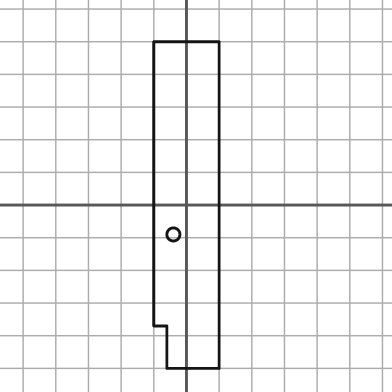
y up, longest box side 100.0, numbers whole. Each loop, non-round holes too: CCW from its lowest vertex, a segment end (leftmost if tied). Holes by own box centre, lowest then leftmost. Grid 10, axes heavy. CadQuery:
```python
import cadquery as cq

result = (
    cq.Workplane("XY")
    .moveTo(-6.0, -50.0)
    .lineTo(10.0, -50.0)
    .lineTo(10.0, 50.0)
    .lineTo(-10.0, 50.0)
    .lineTo(-10.0, -37.0)
    .lineTo(-6.0, -37.0)
    .close()
    .moveTo(-4.0, -9.0)
    .circle(2.0)
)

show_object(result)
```